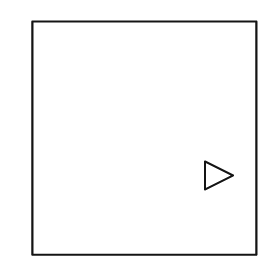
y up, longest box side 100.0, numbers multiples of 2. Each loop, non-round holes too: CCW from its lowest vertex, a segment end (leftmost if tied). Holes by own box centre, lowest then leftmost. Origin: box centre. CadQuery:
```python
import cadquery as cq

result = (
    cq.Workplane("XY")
    .moveTo(-48.0, -50.0)
    .lineTo(48.0, -50.0)
    .lineTo(48.0, 50.0)
    .lineTo(-48.0, 50.0)
    .close()
    .moveTo(26.0, -22.0)
    .lineTo(38.0, -16.0)
    .lineTo(26.0, -10.0)
    .close()
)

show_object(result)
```